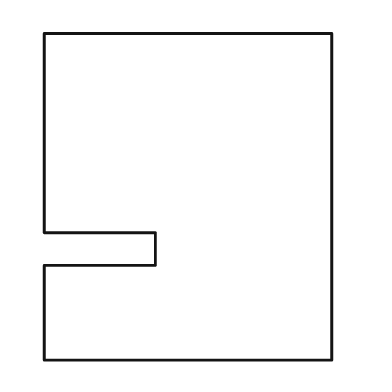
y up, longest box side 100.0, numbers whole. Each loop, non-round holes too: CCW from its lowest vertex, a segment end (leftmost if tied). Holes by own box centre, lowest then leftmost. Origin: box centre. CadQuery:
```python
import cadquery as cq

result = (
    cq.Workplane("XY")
    .moveTo(-44.0, -50.0)
    .lineTo(44.0, -50.0)
    .lineTo(44.0, 50.0)
    .lineTo(-44.0, 50.0)
    .lineTo(-44.0, -11.0)
    .lineTo(-10.0, -11.0)
    .lineTo(-10.0, -21.0)
    .lineTo(-44.0, -21.0)
    .close()
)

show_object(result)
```